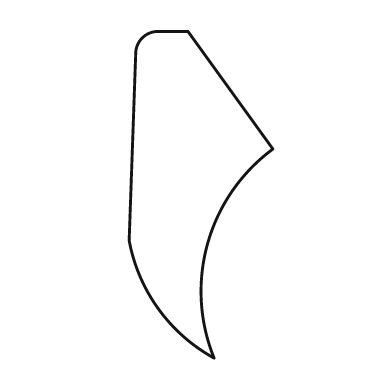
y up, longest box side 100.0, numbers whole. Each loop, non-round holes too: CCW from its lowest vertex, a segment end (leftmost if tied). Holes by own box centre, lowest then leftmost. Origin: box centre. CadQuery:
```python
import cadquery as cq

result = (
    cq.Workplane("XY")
    .moveTo(4.0, -50.0)
    .threePointArc((2.0, -15.0), (22.0, 14.0))
    .lineTo(-4.0, 50.0)
    .lineTo(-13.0, 50.0)
    .threePointArc((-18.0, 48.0), (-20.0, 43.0))
    .lineTo(-22.0, -14.0)
    .threePointArc((-13.0, -35.0), (4.0, -50.0))
    .close()
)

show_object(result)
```